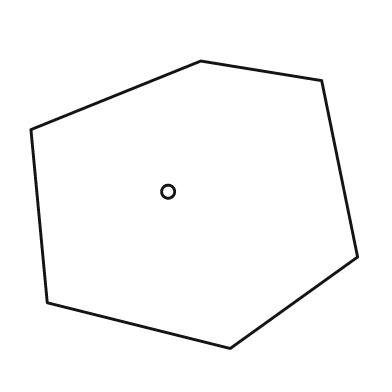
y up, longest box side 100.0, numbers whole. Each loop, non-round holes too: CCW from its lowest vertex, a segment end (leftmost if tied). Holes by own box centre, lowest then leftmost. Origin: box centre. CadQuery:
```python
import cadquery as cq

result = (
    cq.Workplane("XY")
    .moveTo(11.0, -44.0)
    .lineTo(50.0, -16.0)
    .lineTo(39.0, 38.0)
    .lineTo(2.0, 44.0)
    .lineTo(-50.0, 23.0)
    .lineTo(-45.0, -30.0)
    .close()
    .moveTo(-8.0, 4.0)
    .circle(2.0)
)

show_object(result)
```